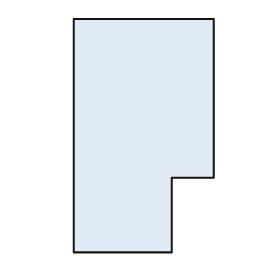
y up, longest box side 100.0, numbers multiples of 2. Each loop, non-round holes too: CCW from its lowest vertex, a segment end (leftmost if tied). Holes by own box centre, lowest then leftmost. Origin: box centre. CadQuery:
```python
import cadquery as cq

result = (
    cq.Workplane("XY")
    .moveTo(-30.0, -50.0)
    .lineTo(12.0, -50.0)
    .lineTo(12.0, -18.0)
    .lineTo(30.0, -18.0)
    .lineTo(30.0, 50.0)
    .lineTo(-30.0, 50.0)
    .close()
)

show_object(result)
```